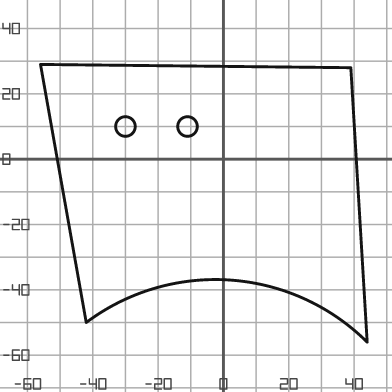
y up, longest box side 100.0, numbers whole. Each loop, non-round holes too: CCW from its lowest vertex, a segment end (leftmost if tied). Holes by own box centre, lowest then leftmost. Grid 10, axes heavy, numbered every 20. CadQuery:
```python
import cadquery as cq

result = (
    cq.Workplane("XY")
    .moveTo(44.0, -56.0)
    .lineTo(39.0, 28.0)
    .lineTo(-56.0, 29.0)
    .lineTo(-42.0, -50.0)
    .threePointArc((2.0, -37.0), (44.0, -56.0))
    .close()
    .moveTo(-30.0, 10.0)
    .circle(3.0)
    .moveTo(-11.0, 10.0)
    .circle(3.0)
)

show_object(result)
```